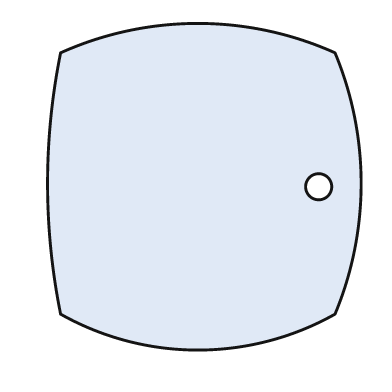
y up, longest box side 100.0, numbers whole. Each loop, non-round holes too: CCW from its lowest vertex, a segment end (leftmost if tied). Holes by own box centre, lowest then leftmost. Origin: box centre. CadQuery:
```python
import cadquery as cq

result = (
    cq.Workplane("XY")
    .moveTo(-44.0, -39.0)
    .threePointArc((-2.0, -50.0), (40.0, -39.0))
    .threePointArc((48.0, 1.0), (40.0, 41.0))
    .threePointArc((-2.0, 50.0), (-44.0, 41.0))
    .threePointArc((-48.0, 1.0), (-44.0, -39.0))
    .close()
    .moveTo(35.0, 0.0)
    .circle(4.0)
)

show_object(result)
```